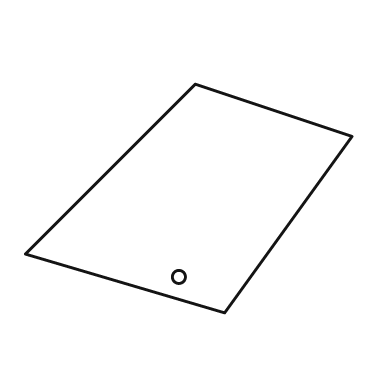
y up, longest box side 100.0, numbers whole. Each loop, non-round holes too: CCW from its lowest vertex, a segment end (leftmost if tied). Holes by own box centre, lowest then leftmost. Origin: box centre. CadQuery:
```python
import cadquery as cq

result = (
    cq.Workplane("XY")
    .moveTo(11.0, -35.0)
    .lineTo(50.0, 19.0)
    .lineTo(2.0, 35.0)
    .lineTo(-50.0, -17.0)
    .close()
    .moveTo(-3.0, -24.0)
    .circle(2.0)
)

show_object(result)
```